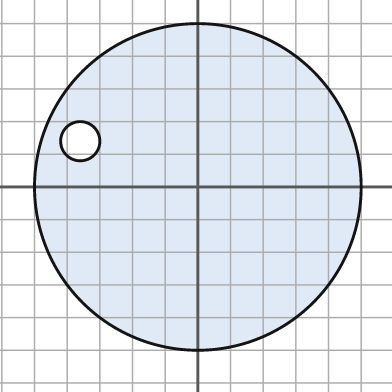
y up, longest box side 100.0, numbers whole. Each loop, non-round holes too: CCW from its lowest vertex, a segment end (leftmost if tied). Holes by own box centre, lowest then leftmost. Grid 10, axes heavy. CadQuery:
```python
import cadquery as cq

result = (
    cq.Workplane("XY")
    .moveTo(0.0, 0.0)
    .circle(50.0)
    .moveTo(-36.0, 14.0)
    .circle(6.0)
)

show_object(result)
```